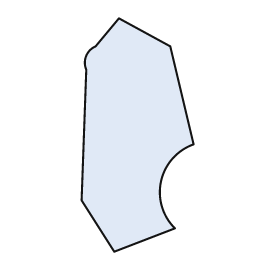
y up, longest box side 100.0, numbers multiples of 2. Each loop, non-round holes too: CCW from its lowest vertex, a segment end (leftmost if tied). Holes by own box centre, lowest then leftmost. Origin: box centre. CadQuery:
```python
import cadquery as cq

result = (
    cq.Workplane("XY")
    .moveTo(-10.0, -50.0)
    .lineTo(16.0, -40.0)
    .threePointArc((10.0, -20.0), (24.0, -4.0))
    .lineTo(14.0, 38.0)
    .lineTo(-8.0, 50.0)
    .lineTo(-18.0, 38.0)
    .threePointArc((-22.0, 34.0), (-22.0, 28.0))
    .lineTo(-24.0, -28.0)
    .close()
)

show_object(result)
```